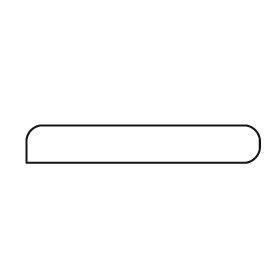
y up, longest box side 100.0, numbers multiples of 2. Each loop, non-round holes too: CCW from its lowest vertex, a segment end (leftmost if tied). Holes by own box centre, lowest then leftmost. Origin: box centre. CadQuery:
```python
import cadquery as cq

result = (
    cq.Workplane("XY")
    .moveTo(-50.0, -8.0)
    .lineTo(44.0, -8.0)
    .threePointArc((48.0, -6.0), (50.0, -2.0))
    .lineTo(50.0, 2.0)
    .threePointArc((48.0, 6.0), (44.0, 8.0))
    .lineTo(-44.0, 8.0)
    .threePointArc((-48.0, 6.0), (-50.0, 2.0))
    .close()
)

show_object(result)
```